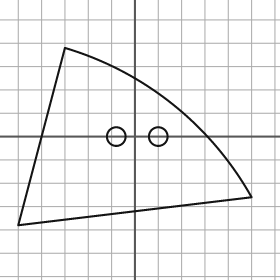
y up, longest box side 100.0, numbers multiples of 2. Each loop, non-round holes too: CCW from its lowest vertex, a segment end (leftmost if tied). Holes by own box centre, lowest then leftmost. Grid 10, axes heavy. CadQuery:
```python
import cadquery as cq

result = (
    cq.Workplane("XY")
    .moveTo(-50.0, -38.0)
    .lineTo(50.0, -26.0)
    .threePointArc((16.0, 14.0), (-30.0, 38.0))
    .close()
    .moveTo(-8.0, 0.0)
    .circle(4.0)
    .moveTo(10.0, 0.0)
    .circle(4.0)
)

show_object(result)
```